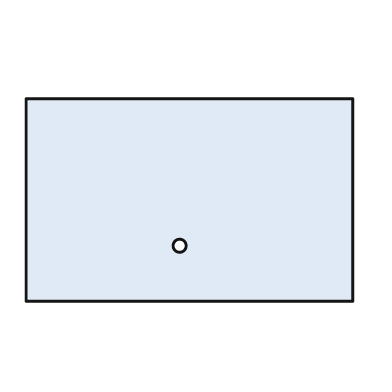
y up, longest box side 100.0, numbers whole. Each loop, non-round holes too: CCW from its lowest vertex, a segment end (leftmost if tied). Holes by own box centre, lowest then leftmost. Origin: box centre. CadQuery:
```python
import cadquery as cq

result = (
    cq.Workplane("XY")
    .moveTo(-50.0, -31.0)
    .lineTo(50.0, -31.0)
    .lineTo(50.0, 31.0)
    .lineTo(-50.0, 31.0)
    .close()
    .moveTo(-3.0, -14.0)
    .circle(2.0)
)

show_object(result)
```